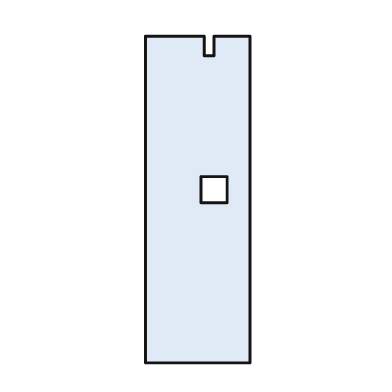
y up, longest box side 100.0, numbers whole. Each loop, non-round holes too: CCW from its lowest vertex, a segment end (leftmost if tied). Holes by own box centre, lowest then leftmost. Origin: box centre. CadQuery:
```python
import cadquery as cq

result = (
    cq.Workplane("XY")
    .moveTo(-16.0, -50.0)
    .lineTo(16.0, -50.0)
    .lineTo(16.0, 50.0)
    .lineTo(5.0, 50.0)
    .lineTo(5.0, 44.0)
    .lineTo(2.0, 44.0)
    .lineTo(2.0, 50.0)
    .lineTo(-16.0, 50.0)
    .close()
    .moveTo(1.0, -1.0)
    .lineTo(9.0, -1.0)
    .lineTo(9.0, 7.0)
    .lineTo(1.0, 7.0)
    .close()
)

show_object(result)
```